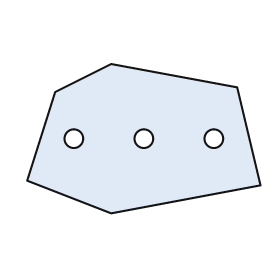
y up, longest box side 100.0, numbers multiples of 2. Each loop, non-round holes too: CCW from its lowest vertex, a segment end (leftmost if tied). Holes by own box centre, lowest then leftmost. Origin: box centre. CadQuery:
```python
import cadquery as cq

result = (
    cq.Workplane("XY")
    .moveTo(-14.0, -32.0)
    .lineTo(50.0, -20.0)
    .lineTo(40.0, 22.0)
    .lineTo(-14.0, 32.0)
    .lineTo(-38.0, 20.0)
    .lineTo(-50.0, -18.0)
    .close()
    .moveTo(-30.0, 0.0)
    .circle(4.0)
    .moveTo(0.0, 0.0)
    .circle(4.0)
    .moveTo(30.0, 0.0)
    .circle(4.0)
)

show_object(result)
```